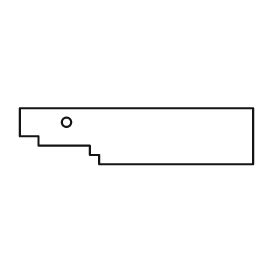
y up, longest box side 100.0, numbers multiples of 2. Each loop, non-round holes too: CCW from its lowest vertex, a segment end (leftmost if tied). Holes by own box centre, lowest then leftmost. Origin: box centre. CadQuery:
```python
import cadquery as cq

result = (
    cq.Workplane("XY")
    .moveTo(-16.0, -12.0)
    .lineTo(50.0, -12.0)
    .lineTo(50.0, 12.0)
    .lineTo(-50.0, 12.0)
    .lineTo(-50.0, 0.0)
    .lineTo(-42.0, 0.0)
    .lineTo(-42.0, -4.0)
    .lineTo(-20.0, -4.0)
    .lineTo(-20.0, -8.0)
    .lineTo(-16.0, -8.0)
    .close()
    .moveTo(-30.0, 6.0)
    .circle(2.0)
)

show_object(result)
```